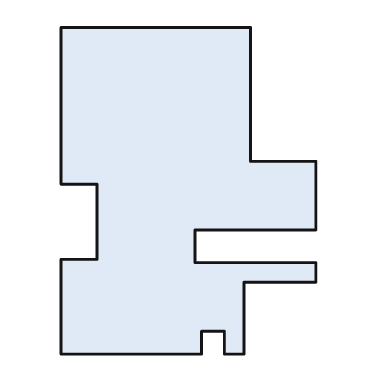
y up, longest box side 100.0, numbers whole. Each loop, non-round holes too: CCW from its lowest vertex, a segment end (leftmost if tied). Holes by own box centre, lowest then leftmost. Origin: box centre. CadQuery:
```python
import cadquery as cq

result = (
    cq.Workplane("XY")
    .moveTo(-39.0, -50.0)
    .lineTo(4.0, -50.0)
    .lineTo(4.0, -43.0)
    .lineTo(11.0, -43.0)
    .lineTo(11.0, -50.0)
    .lineTo(17.0, -50.0)
    .lineTo(17.0, -28.0)
    .lineTo(39.0, -28.0)
    .lineTo(39.0, -22.0)
    .lineTo(2.0, -22.0)
    .lineTo(2.0, -12.0)
    .lineTo(39.0, -12.0)
    .lineTo(39.0, 9.0)
    .lineTo(19.0, 9.0)
    .lineTo(19.0, 50.0)
    .lineTo(-39.0, 50.0)
    .lineTo(-39.0, 2.0)
    .lineTo(-28.0, 2.0)
    .lineTo(-28.0, -21.0)
    .lineTo(-39.0, -21.0)
    .close()
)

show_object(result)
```